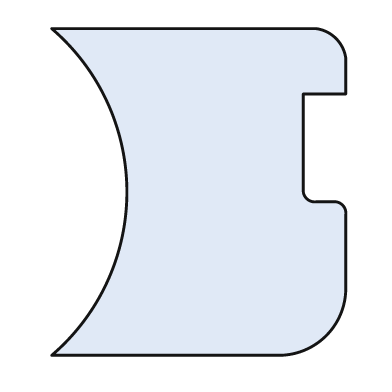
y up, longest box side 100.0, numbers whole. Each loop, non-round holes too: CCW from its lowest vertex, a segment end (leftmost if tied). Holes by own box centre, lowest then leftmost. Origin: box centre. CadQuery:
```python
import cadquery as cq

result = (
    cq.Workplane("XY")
    .moveTo(-45.0, -50.0)
    .lineTo(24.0, -50.0)
    .threePointArc((39.0, -44.0), (45.0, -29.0))
    .lineTo(45.0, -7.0)
    .threePointArc((44.0, -4.0), (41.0, -3.0))
    .lineTo(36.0, -3.0)
    .threePointArc((33.0, -2.0), (32.0, 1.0))
    .lineTo(32.0, 30.0)
    .lineTo(45.0, 30.0)
    .lineTo(45.0, 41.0)
    .threePointArc((42.0, 47.0), (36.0, 50.0))
    .lineTo(-45.0, 50.0)
    .threePointArc((-22.0, 0.0), (-45.0, -50.0))
    .close()
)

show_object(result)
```